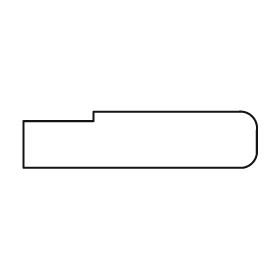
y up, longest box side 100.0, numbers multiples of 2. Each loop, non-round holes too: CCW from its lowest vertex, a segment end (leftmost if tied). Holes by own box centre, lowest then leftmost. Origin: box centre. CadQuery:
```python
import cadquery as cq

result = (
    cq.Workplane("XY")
    .moveTo(-50.0, -12.0)
    .lineTo(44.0, -12.0)
    .threePointArc((48.0, -10.0), (50.0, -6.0))
    .lineTo(50.0, 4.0)
    .threePointArc((48.0, 10.0), (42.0, 12.0))
    .lineTo(-20.0, 12.0)
    .lineTo(-20.0, 8.0)
    .lineTo(-50.0, 8.0)
    .close()
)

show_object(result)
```